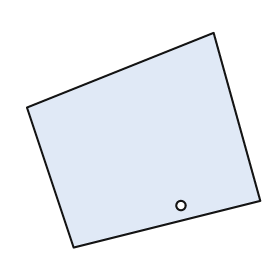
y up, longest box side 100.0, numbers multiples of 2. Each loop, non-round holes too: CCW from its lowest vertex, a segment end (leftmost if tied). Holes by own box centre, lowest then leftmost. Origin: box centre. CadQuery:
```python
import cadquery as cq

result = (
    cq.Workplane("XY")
    .moveTo(-30.0, -46.0)
    .lineTo(50.0, -26.0)
    .lineTo(30.0, 46.0)
    .lineTo(-50.0, 14.0)
    .close()
    .moveTo(16.0, -28.0)
    .circle(2.0)
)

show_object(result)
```